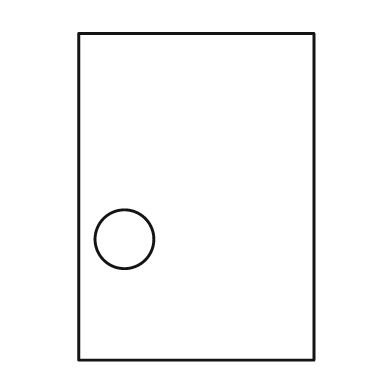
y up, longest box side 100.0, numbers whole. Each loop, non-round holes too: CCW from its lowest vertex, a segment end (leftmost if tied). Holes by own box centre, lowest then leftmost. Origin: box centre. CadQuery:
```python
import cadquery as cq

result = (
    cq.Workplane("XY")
    .moveTo(-36.0, -50.0)
    .lineTo(36.0, -50.0)
    .lineTo(36.0, 50.0)
    .lineTo(-36.0, 50.0)
    .close()
    .moveTo(-22.0, -13.0)
    .circle(9.0)
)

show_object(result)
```